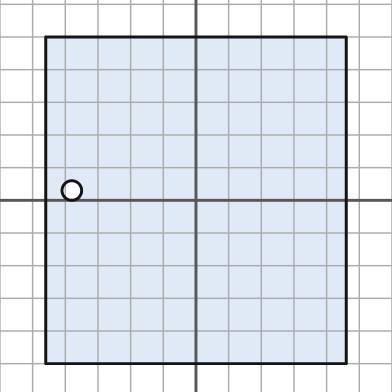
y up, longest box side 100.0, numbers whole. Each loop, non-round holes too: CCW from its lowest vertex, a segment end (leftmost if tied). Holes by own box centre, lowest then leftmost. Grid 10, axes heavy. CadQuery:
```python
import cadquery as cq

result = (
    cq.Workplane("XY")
    .moveTo(-46.0, -50.0)
    .lineTo(46.0, -50.0)
    .lineTo(46.0, 50.0)
    .lineTo(-46.0, 50.0)
    .close()
    .moveTo(-38.0, 3.0)
    .circle(3.0)
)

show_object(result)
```